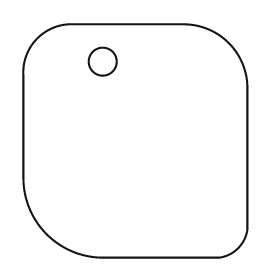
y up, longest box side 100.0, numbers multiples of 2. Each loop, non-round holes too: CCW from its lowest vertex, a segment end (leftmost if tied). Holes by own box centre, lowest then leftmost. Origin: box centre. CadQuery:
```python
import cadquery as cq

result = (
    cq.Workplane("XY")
    .moveTo(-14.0, -50.0)
    .lineTo(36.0, -50.0)
    .threePointArc((44.0, -46.0), (48.0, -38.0))
    .lineTo(48.0, 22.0)
    .threePointArc((40.0, 42.0), (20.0, 50.0))
    .lineTo(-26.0, 50.0)
    .threePointArc((-42.0, 44.0), (-48.0, 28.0))
    .lineTo(-48.0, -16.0)
    .threePointArc((-38.0, -40.0), (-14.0, -50.0))
    .close()
    .moveTo(-14.0, 34.0)
    .circle(6.0)
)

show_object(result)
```